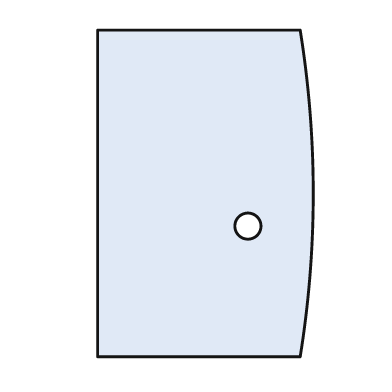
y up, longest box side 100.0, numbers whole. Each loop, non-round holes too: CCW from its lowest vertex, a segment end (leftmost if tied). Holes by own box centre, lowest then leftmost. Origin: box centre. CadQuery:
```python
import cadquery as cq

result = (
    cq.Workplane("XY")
    .moveTo(-33.0, -50.0)
    .lineTo(29.0, -50.0)
    .threePointArc((33.0, 0.0), (29.0, 50.0))
    .lineTo(-33.0, 50.0)
    .close()
    .moveTo(13.0, -10.0)
    .circle(4.0)
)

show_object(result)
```